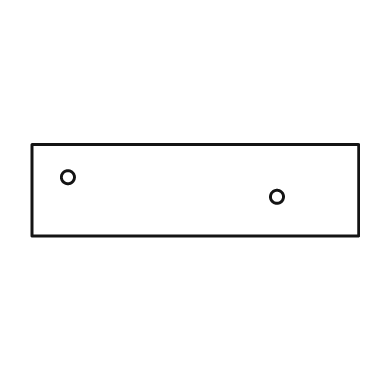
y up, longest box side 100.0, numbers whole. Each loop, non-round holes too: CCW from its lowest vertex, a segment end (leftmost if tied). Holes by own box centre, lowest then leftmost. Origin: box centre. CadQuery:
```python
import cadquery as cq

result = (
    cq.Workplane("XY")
    .moveTo(-50.0, -14.0)
    .lineTo(50.0, -14.0)
    .lineTo(50.0, 14.0)
    .lineTo(-50.0, 14.0)
    .close()
    .moveTo(25.0, -2.0)
    .circle(2.0)
    .moveTo(-39.0, 4.0)
    .circle(2.0)
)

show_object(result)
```